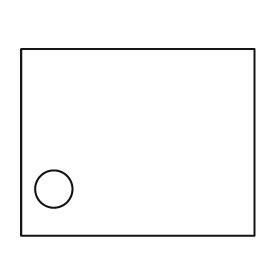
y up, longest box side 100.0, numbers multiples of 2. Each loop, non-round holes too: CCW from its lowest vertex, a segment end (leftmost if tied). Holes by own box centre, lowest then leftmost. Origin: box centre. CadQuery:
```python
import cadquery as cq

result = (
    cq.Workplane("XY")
    .moveTo(-50.0, -40.0)
    .lineTo(50.0, -40.0)
    .lineTo(50.0, 40.0)
    .lineTo(-50.0, 40.0)
    .close()
    .moveTo(-36.0, -20.0)
    .circle(8.0)
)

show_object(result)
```